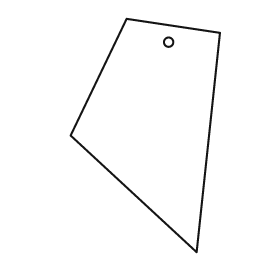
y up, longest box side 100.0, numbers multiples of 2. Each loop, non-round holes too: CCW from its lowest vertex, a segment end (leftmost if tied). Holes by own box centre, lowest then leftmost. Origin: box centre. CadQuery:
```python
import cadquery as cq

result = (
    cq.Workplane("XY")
    .moveTo(22.0, -50.0)
    .lineTo(32.0, 44.0)
    .lineTo(-8.0, 50.0)
    .lineTo(-32.0, 0.0)
    .close()
    .moveTo(10.0, 40.0)
    .circle(2.0)
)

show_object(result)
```